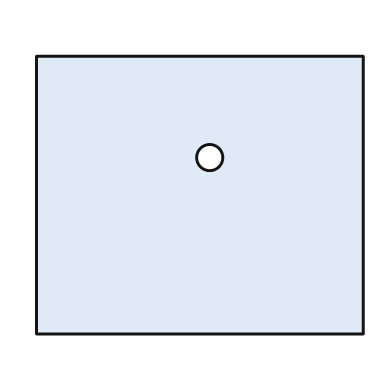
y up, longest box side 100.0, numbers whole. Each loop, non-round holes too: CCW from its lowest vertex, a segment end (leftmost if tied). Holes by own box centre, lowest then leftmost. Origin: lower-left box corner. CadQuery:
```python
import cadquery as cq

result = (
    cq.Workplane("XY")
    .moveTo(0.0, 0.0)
    .lineTo(100.0, 0.0)
    .lineTo(100.0, 85.0)
    .lineTo(0.0, 85.0)
    .close()
    .moveTo(53.0, 54.0)
    .circle(4.0)
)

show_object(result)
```